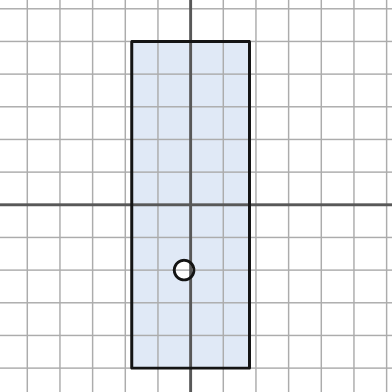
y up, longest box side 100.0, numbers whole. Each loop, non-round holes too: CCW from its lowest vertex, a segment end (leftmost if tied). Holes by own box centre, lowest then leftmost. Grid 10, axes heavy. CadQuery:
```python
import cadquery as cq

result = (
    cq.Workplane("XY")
    .moveTo(-18.0, -50.0)
    .lineTo(18.0, -50.0)
    .lineTo(18.0, 50.0)
    .lineTo(-18.0, 50.0)
    .close()
    .moveTo(-2.0, -20.0)
    .circle(3.0)
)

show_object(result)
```